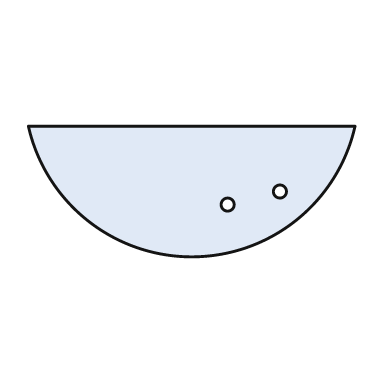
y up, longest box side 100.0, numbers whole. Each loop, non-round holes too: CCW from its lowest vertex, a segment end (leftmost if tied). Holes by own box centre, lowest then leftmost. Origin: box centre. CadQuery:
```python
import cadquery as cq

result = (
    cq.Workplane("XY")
    .moveTo(-50.0, 20.0)
    .threePointArc((0.0, -20.0), (50.0, 20.0))
    .close()
    .moveTo(11.0, -4.0)
    .circle(2.0)
    .moveTo(27.0, 0.0)
    .circle(2.0)
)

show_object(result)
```